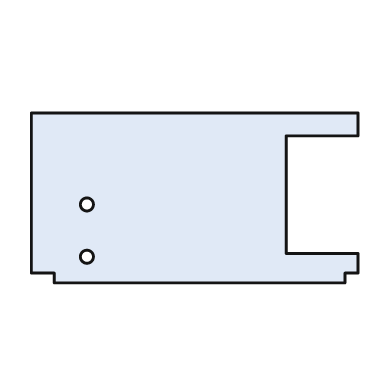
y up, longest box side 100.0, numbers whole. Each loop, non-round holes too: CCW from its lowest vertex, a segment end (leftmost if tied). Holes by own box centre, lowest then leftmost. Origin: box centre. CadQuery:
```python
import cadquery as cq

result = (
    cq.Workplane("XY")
    .moveTo(-43.0, -26.0)
    .lineTo(46.0, -26.0)
    .lineTo(46.0, -23.0)
    .lineTo(50.0, -23.0)
    .lineTo(50.0, -17.0)
    .lineTo(28.0, -17.0)
    .lineTo(28.0, 19.0)
    .lineTo(50.0, 19.0)
    .lineTo(50.0, 26.0)
    .lineTo(-50.0, 26.0)
    .lineTo(-50.0, -23.0)
    .lineTo(-43.0, -23.0)
    .close()
    .moveTo(-33.0, -18.0)
    .circle(2.0)
    .moveTo(-33.0, -2.0)
    .circle(2.0)
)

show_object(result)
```